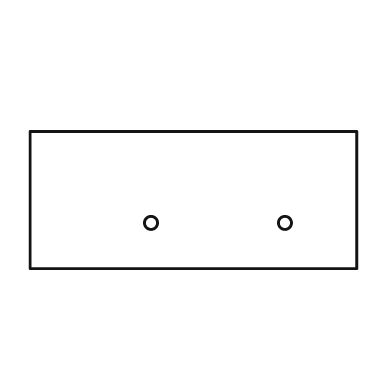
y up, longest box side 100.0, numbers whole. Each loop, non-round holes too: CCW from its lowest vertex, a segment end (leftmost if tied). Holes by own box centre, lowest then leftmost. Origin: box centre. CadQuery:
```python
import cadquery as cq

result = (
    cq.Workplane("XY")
    .moveTo(-50.0, -21.0)
    .lineTo(50.0, -21.0)
    .lineTo(50.0, 21.0)
    .lineTo(-50.0, 21.0)
    .close()
    .moveTo(-13.0, -7.0)
    .circle(2.0)
    .moveTo(28.0, -7.0)
    .circle(2.0)
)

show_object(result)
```